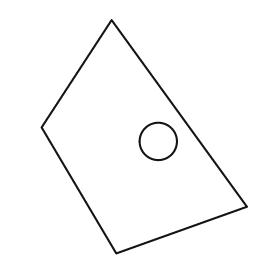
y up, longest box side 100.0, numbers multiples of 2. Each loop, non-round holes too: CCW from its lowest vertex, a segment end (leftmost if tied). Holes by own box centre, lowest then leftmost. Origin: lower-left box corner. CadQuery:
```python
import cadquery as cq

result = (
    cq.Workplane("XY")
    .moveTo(32.0, 0.0)
    .lineTo(88.0, 20.0)
    .lineTo(30.0, 100.0)
    .lineTo(0.0, 54.0)
    .close()
    .moveTo(50.0, 48.0)
    .circle(8.0)
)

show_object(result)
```